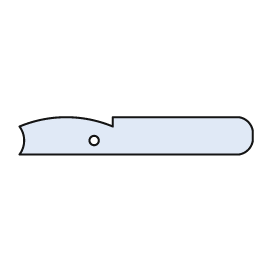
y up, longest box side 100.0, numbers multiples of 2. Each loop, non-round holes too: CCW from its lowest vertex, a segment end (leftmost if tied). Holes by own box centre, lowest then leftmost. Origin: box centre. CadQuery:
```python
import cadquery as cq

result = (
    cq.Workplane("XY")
    .moveTo(-50.0, -8.0)
    .lineTo(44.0, -8.0)
    .threePointArc((48.0, -6.0), (50.0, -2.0))
    .lineTo(50.0, 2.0)
    .threePointArc((48.0, 6.0), (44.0, 8.0))
    .lineTo(-10.0, 8.0)
    .lineTo(-10.0, 4.0)
    .threePointArc((-30.0, 8.0), (-50.0, 4.0))
    .threePointArc((-48.0, -2.0), (-50.0, -8.0))
    .close()
    .moveTo(-18.0, -2.0)
    .circle(2.0)
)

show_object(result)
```